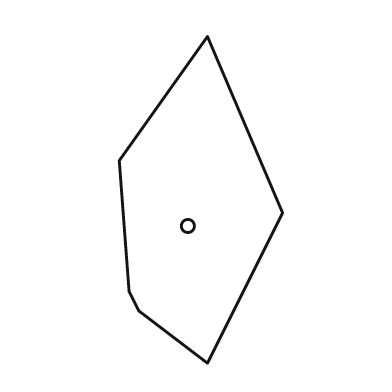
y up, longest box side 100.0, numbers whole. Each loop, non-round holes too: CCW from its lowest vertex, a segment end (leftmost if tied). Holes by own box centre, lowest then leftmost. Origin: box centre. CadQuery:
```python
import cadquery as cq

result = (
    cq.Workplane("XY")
    .moveTo(2.0, -50.0)
    .lineTo(25.0, -4.0)
    .lineTo(2.0, 50.0)
    .lineTo(-25.0, 12.0)
    .lineTo(-22.0, -28.0)
    .lineTo(-19.0, -34.0)
    .close()
    .moveTo(-4.0, -8.0)
    .circle(2.0)
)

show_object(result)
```